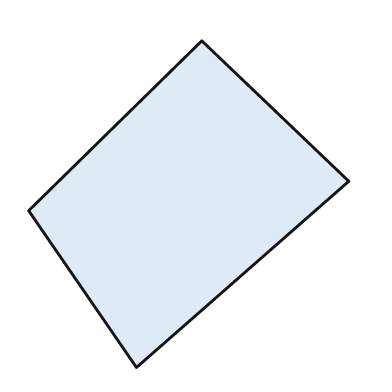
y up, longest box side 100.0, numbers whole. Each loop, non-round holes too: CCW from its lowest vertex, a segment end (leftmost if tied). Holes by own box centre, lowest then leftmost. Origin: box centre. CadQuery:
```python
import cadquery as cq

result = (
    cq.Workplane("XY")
    .moveTo(-16.0, -50.0)
    .lineTo(49.0, 7.0)
    .lineTo(4.0, 50.0)
    .lineTo(-49.0, -2.0)
    .close()
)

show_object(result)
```